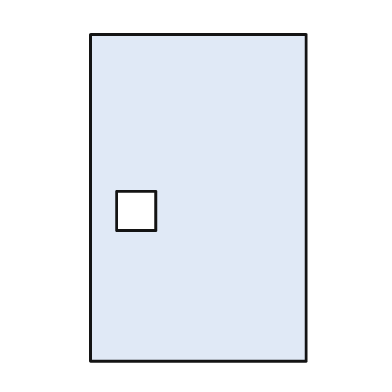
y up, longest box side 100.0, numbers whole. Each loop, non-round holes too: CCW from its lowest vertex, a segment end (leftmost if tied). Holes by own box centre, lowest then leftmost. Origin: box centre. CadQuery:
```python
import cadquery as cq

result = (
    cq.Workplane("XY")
    .moveTo(-33.0, -50.0)
    .lineTo(33.0, -50.0)
    .lineTo(33.0, 50.0)
    .lineTo(-33.0, 50.0)
    .close()
    .moveTo(-25.0, -10.0)
    .lineTo(-13.0, -10.0)
    .lineTo(-13.0, 2.0)
    .lineTo(-25.0, 2.0)
    .close()
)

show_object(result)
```